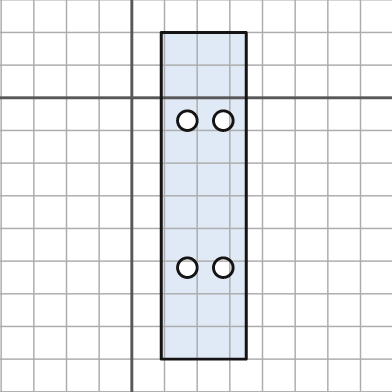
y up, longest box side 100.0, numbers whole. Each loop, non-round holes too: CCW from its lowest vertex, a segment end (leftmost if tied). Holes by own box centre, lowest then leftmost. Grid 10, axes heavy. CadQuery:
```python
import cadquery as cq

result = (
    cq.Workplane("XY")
    .moveTo(9.0, -80.0)
    .lineTo(35.0, -80.0)
    .lineTo(35.0, 20.0)
    .lineTo(9.0, 20.0)
    .close()
    .moveTo(17.0, -52.0)
    .circle(3.0)
    .moveTo(28.0, -52.0)
    .circle(3.0)
    .moveTo(17.0, -7.0)
    .circle(3.0)
    .moveTo(28.0, -7.0)
    .circle(3.0)
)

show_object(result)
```